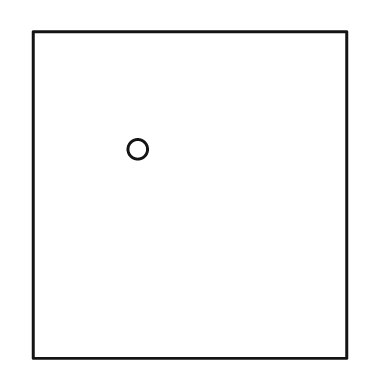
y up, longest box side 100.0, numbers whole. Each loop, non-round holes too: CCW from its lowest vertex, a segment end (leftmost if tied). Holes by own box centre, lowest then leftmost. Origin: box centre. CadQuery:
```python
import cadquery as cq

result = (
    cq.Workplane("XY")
    .moveTo(-48.0, -50.0)
    .lineTo(48.0, -50.0)
    .lineTo(48.0, 50.0)
    .lineTo(-48.0, 50.0)
    .close()
    .moveTo(-16.0, 14.0)
    .circle(3.0)
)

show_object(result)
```